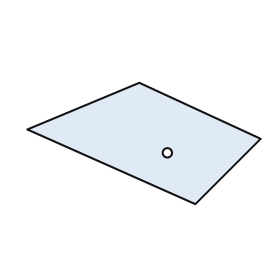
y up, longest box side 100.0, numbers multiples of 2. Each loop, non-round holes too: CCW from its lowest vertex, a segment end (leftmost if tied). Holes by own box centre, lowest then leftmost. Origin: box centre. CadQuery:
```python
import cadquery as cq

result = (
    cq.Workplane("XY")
    .moveTo(22.0, -26.0)
    .lineTo(50.0, 2.0)
    .lineTo(-2.0, 26.0)
    .lineTo(-50.0, 6.0)
    .close()
    .moveTo(10.0, -4.0)
    .circle(2.0)
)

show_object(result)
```